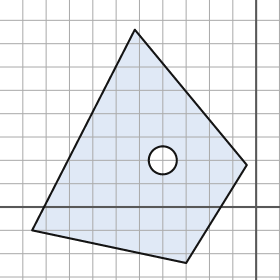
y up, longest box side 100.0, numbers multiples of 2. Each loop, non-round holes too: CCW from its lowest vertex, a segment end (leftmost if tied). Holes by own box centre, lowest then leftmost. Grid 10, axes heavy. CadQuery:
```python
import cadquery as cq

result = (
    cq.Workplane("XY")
    .moveTo(-30.0, -24.0)
    .lineTo(-4.0, 18.0)
    .lineTo(-52.0, 76.0)
    .lineTo(-96.0, -10.0)
    .close()
    .moveTo(-40.0, 20.0)
    .circle(6.0)
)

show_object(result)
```